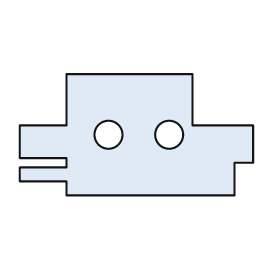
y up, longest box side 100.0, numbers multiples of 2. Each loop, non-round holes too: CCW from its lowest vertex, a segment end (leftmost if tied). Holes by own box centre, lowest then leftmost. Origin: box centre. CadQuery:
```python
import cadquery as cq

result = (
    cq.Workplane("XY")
    .moveTo(-30.0, -26.0)
    .lineTo(42.0, -26.0)
    .lineTo(42.0, -12.0)
    .lineTo(50.0, -12.0)
    .lineTo(50.0, 4.0)
    .lineTo(24.0, 4.0)
    .lineTo(24.0, 26.0)
    .lineTo(-30.0, 26.0)
    .lineTo(-30.0, 4.0)
    .lineTo(-50.0, 4.0)
    .lineTo(-50.0, -10.0)
    .lineTo(-30.0, -10.0)
    .lineTo(-30.0, -14.0)
    .lineTo(-50.0, -14.0)
    .lineTo(-50.0, -20.0)
    .lineTo(-30.0, -20.0)
    .close()
    .moveTo(-12.0, 0.0)
    .circle(6.0)
    .moveTo(14.0, 0.0)
    .circle(6.0)
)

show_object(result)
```